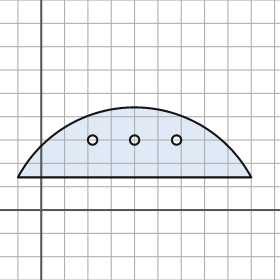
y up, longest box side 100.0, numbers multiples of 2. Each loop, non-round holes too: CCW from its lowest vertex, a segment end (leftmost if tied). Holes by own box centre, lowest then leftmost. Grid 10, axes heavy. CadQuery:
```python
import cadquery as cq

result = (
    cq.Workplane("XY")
    .moveTo(-10.0, 14.0)
    .lineTo(90.0, 14.0)
    .threePointArc((40.0, 44.0), (-10.0, 14.0))
    .close()
    .moveTo(22.0, 30.0)
    .circle(2.0)
    .moveTo(40.0, 30.0)
    .circle(2.0)
    .moveTo(58.0, 30.0)
    .circle(2.0)
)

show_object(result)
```